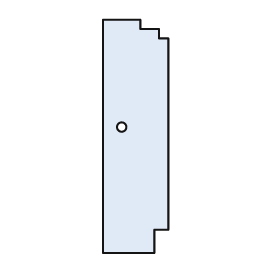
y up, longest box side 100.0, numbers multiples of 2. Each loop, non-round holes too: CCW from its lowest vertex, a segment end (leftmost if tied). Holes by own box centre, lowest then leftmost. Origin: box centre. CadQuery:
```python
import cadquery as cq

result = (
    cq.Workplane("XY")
    .moveTo(-14.0, -50.0)
    .lineTo(8.0, -50.0)
    .lineTo(8.0, -40.0)
    .lineTo(14.0, -40.0)
    .lineTo(14.0, 42.0)
    .lineTo(10.0, 42.0)
    .lineTo(10.0, 46.0)
    .lineTo(2.0, 46.0)
    .lineTo(2.0, 50.0)
    .lineTo(-14.0, 50.0)
    .close()
    .moveTo(-6.0, 4.0)
    .circle(2.0)
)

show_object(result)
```